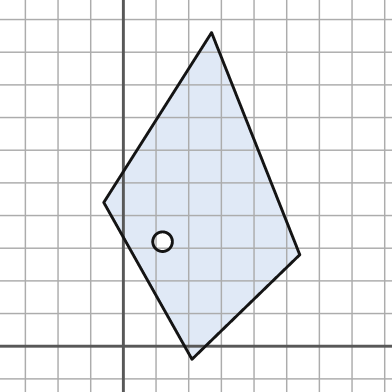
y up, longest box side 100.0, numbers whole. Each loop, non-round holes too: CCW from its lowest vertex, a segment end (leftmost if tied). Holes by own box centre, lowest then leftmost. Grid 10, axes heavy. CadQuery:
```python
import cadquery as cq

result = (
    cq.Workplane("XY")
    .moveTo(21.0, -4.0)
    .lineTo(54.0, 28.0)
    .lineTo(27.0, 96.0)
    .lineTo(-6.0, 44.0)
    .close()
    .moveTo(12.0, 32.0)
    .circle(3.0)
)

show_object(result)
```